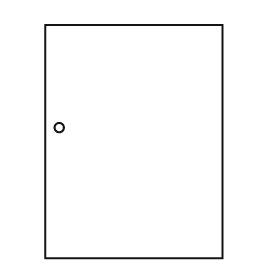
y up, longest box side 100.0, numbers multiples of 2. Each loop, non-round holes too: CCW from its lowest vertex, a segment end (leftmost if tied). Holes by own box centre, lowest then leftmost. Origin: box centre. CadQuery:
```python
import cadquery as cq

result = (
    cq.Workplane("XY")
    .moveTo(-38.0, -50.0)
    .lineTo(38.0, -50.0)
    .lineTo(38.0, 50.0)
    .lineTo(-38.0, 50.0)
    .close()
    .moveTo(-32.0, 6.0)
    .circle(2.0)
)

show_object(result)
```